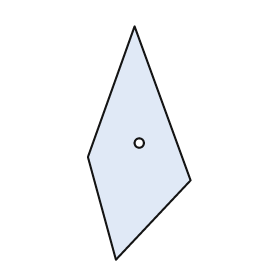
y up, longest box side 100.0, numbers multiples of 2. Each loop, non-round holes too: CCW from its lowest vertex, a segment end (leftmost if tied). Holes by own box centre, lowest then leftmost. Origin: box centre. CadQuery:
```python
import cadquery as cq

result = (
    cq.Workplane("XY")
    .moveTo(-10.0, -50.0)
    .lineTo(22.0, -16.0)
    .lineTo(-2.0, 50.0)
    .lineTo(-22.0, -6.0)
    .close()
    .moveTo(0.0, 0.0)
    .circle(2.0)
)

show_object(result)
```